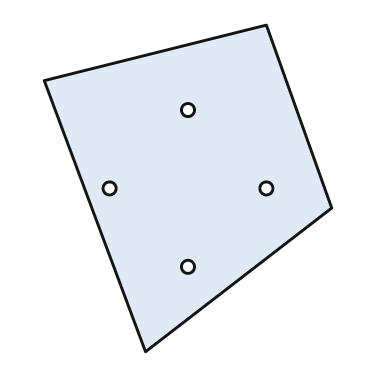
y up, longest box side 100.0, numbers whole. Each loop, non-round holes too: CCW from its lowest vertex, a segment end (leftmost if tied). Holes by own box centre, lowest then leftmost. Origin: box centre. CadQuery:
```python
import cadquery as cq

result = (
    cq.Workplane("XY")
    .moveTo(-13.0, -50.0)
    .lineTo(44.0, -6.0)
    .lineTo(24.0, 50.0)
    .lineTo(-44.0, 33.0)
    .close()
    .moveTo(0.0, -24.0)
    .circle(2.0)
    .moveTo(-24.0, 0.0)
    .circle(2.0)
    .moveTo(24.0, 0.0)
    .circle(2.0)
    .moveTo(0.0, 24.0)
    .circle(2.0)
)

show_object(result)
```